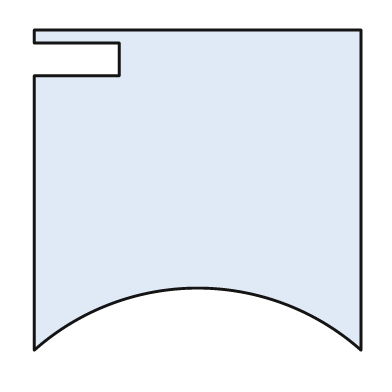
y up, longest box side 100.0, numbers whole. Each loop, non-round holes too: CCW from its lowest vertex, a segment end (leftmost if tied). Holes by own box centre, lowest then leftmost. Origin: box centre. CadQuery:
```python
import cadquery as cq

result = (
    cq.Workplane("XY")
    .moveTo(-50.0, -49.0)
    .threePointArc((0.0, -30.0), (50.0, -49.0))
    .lineTo(50.0, 49.0)
    .lineTo(-50.0, 49.0)
    .lineTo(-50.0, 45.0)
    .lineTo(-24.0, 45.0)
    .lineTo(-24.0, 35.0)
    .lineTo(-50.0, 35.0)
    .close()
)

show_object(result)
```